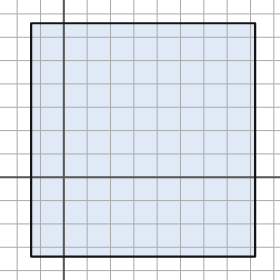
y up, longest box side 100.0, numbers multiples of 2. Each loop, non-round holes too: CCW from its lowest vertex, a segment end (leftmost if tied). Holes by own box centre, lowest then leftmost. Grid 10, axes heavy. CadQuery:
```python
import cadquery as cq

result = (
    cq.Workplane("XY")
    .moveTo(-14.0, -34.0)
    .lineTo(82.0, -34.0)
    .lineTo(82.0, 66.0)
    .lineTo(-14.0, 66.0)
    .close()
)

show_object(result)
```